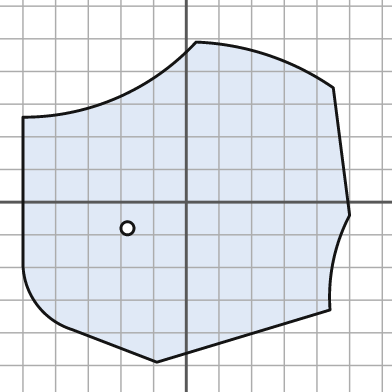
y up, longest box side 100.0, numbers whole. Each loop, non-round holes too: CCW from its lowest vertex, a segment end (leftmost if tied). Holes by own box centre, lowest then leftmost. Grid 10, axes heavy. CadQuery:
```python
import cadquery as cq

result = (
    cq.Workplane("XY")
    .moveTo(-9.0, -49.0)
    .lineTo(44.0, -33.0)
    .threePointArc((45.0, -18.0), (50.0, -4.0))
    .lineTo(45.0, 35.0)
    .threePointArc((25.0, 45.0), (3.0, 49.0))
    .threePointArc((-21.0, 32.0), (-50.0, 26.0))
    .lineTo(-50.0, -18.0)
    .threePointArc((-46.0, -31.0), (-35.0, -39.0))
    .close()
    .moveTo(-18.0, -8.0)
    .circle(2.0)
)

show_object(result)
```